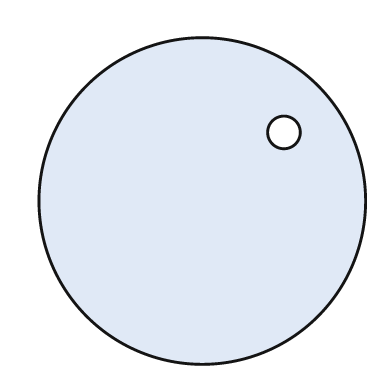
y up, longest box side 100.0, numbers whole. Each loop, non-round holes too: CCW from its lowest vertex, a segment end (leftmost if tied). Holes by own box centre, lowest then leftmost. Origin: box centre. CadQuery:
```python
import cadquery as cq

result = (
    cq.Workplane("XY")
    .moveTo(0.0, 0.0)
    .circle(50.0)
    .moveTo(25.0, 21.0)
    .circle(5.0)
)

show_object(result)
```